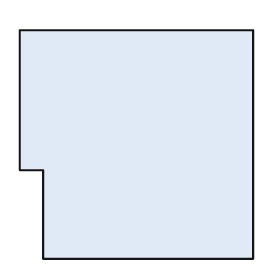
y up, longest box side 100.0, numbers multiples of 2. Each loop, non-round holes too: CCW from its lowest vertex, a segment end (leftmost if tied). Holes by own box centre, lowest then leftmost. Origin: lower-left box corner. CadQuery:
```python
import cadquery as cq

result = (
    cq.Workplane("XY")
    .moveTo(10.0, 0.0)
    .lineTo(100.0, 0.0)
    .lineTo(100.0, 98.0)
    .lineTo(0.0, 98.0)
    .lineTo(0.0, 38.0)
    .lineTo(10.0, 38.0)
    .close()
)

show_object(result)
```